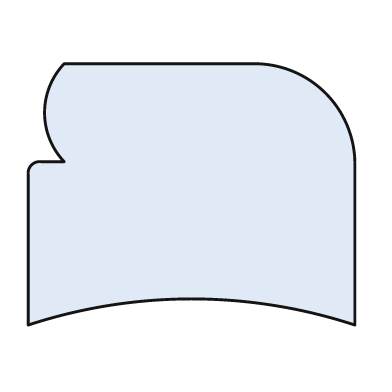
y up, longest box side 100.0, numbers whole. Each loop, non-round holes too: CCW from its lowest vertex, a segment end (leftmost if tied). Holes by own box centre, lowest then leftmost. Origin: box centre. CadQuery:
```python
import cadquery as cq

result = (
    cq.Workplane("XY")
    .moveTo(-50.0, -40.0)
    .threePointArc((0.0, -32.0), (50.0, -40.0))
    .lineTo(50.0, 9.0)
    .threePointArc((41.0, 31.0), (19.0, 40.0))
    .lineTo(-39.0, 40.0)
    .threePointArc((-45.0, 25.0), (-39.0, 10.0))
    .lineTo(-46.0, 10.0)
    .threePointArc((-49.0, 9.0), (-50.0, 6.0))
    .close()
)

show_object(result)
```